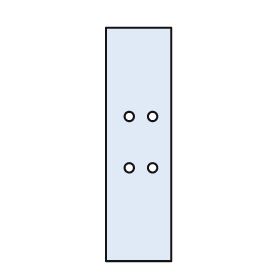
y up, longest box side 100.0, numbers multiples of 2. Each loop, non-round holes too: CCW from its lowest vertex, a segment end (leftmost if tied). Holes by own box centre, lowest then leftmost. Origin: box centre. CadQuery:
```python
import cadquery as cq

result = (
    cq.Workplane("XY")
    .moveTo(-14.0, -50.0)
    .lineTo(14.0, -50.0)
    .lineTo(14.0, 50.0)
    .lineTo(-14.0, 50.0)
    .close()
    .moveTo(-4.0, -10.0)
    .circle(2.0)
    .moveTo(6.0, -10.0)
    .circle(2.0)
    .moveTo(-4.0, 12.0)
    .circle(2.0)
    .moveTo(6.0, 12.0)
    .circle(2.0)
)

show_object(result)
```